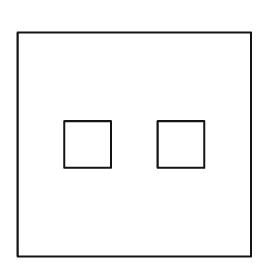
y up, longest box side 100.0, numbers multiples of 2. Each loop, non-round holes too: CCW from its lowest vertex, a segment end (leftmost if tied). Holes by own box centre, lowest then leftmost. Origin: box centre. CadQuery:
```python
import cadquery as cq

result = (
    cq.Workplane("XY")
    .moveTo(-50.0, -48.0)
    .lineTo(50.0, -48.0)
    .lineTo(50.0, 48.0)
    .lineTo(-50.0, 48.0)
    .close()
    .moveTo(-30.0, -10.0)
    .lineTo(-10.0, -10.0)
    .lineTo(-10.0, 10.0)
    .lineTo(-30.0, 10.0)
    .close()
    .moveTo(10.0, -10.0)
    .lineTo(30.0, -10.0)
    .lineTo(30.0, 10.0)
    .lineTo(10.0, 10.0)
    .close()
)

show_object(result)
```